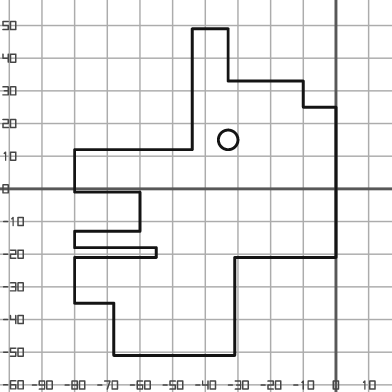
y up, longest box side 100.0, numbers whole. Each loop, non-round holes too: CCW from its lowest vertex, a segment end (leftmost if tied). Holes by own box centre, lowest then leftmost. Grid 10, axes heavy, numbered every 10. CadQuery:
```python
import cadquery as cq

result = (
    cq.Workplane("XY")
    .moveTo(-68.0, -51.0)
    .lineTo(-31.0, -51.0)
    .lineTo(-31.0, -21.0)
    .lineTo(0.0, -21.0)
    .lineTo(0.0, 25.0)
    .lineTo(-10.0, 25.0)
    .lineTo(-10.0, 33.0)
    .lineTo(-33.0, 33.0)
    .lineTo(-33.0, 49.0)
    .lineTo(-44.0, 49.0)
    .lineTo(-44.0, 12.0)
    .lineTo(-80.0, 12.0)
    .lineTo(-80.0, -1.0)
    .lineTo(-60.0, -1.0)
    .lineTo(-60.0, -13.0)
    .lineTo(-80.0, -13.0)
    .lineTo(-80.0, -18.0)
    .lineTo(-55.0, -18.0)
    .lineTo(-55.0, -21.0)
    .lineTo(-80.0, -21.0)
    .lineTo(-80.0, -35.0)
    .lineTo(-68.0, -35.0)
    .close()
    .moveTo(-33.0, 15.0)
    .circle(3.0)
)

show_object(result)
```